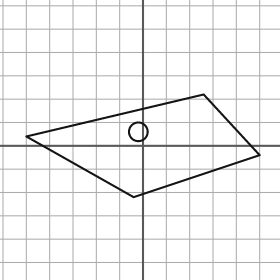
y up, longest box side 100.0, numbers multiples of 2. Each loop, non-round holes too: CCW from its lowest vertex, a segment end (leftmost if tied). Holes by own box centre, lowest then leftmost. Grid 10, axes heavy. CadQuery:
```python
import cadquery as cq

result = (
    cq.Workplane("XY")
    .moveTo(-4.0, -22.0)
    .lineTo(50.0, -4.0)
    .lineTo(26.0, 22.0)
    .lineTo(-50.0, 4.0)
    .close()
    .moveTo(-2.0, 6.0)
    .circle(4.0)
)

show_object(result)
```